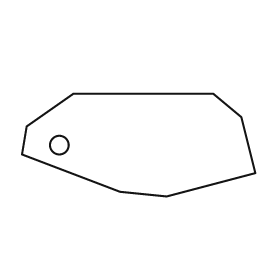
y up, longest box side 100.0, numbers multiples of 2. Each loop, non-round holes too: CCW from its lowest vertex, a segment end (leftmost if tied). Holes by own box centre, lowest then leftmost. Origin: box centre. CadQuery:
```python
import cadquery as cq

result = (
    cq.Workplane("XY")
    .moveTo(12.0, -22.0)
    .lineTo(50.0, -12.0)
    .lineTo(44.0, 12.0)
    .lineTo(32.0, 22.0)
    .lineTo(-28.0, 22.0)
    .lineTo(-48.0, 8.0)
    .lineTo(-50.0, -4.0)
    .lineTo(-8.0, -20.0)
    .close()
    .moveTo(-34.0, 0.0)
    .circle(4.0)
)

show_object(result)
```